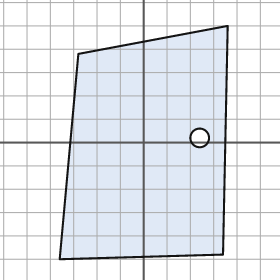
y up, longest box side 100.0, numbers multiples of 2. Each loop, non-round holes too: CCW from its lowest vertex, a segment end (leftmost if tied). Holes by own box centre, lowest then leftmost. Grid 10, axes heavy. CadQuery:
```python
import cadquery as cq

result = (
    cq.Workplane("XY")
    .moveTo(-36.0, -50.0)
    .lineTo(34.0, -48.0)
    .lineTo(36.0, 50.0)
    .lineTo(-28.0, 38.0)
    .close()
    .moveTo(24.0, 2.0)
    .circle(4.0)
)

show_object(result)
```